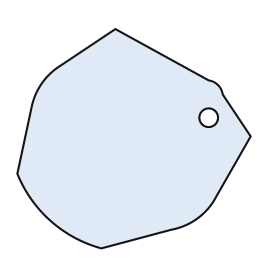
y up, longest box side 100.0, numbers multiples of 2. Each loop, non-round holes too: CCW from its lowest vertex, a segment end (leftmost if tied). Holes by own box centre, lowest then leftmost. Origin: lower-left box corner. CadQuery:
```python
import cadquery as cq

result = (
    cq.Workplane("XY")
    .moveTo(36.0, 0.0)
    .lineTo(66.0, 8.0)
    .threePointArc((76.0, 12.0), (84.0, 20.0))
    .lineTo(100.0, 48.0)
    .lineTo(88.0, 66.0)
    .threePointArc((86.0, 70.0), (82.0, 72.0))
    .lineTo(42.0, 94.0)
    .lineTo(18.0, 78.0)
    .threePointArc((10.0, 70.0), (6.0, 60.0))
    .lineTo(0.0, 32.0)
    .threePointArc((14.0, 12.0), (36.0, 0.0))
    .close()
    .moveTo(82.0, 56.0)
    .circle(4.0)
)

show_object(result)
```